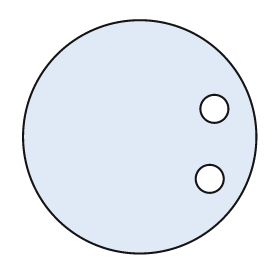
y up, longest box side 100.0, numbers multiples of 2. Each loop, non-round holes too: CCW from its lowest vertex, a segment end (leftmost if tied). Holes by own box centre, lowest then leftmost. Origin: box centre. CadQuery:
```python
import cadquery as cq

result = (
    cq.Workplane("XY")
    .moveTo(0.0, 0.0)
    .circle(50.0)
    .moveTo(30.0, -18.0)
    .circle(6.0)
    .moveTo(32.0, 12.0)
    .circle(6.0)
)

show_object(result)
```